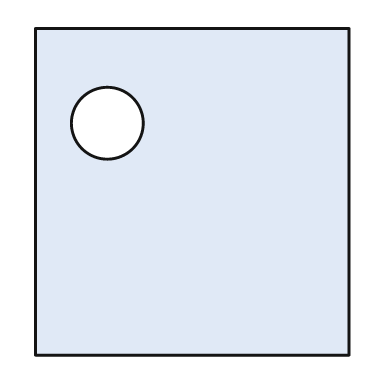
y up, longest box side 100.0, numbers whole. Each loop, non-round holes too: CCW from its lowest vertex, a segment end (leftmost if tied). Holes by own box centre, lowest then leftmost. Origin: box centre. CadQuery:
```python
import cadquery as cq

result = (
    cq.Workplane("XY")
    .moveTo(-48.0, -50.0)
    .lineTo(48.0, -50.0)
    .lineTo(48.0, 50.0)
    .lineTo(-48.0, 50.0)
    .close()
    .moveTo(-26.0, 21.0)
    .circle(11.0)
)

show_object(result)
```